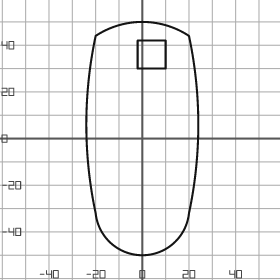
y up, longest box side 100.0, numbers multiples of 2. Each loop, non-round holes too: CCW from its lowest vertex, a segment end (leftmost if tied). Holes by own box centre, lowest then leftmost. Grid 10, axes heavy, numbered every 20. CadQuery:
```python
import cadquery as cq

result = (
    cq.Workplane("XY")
    .moveTo(-20.0, -32.0)
    .threePointArc((0.0, -50.0), (20.0, -32.0))
    .threePointArc((24.0, 6.0), (20.0, 44.0))
    .threePointArc((0.0, 50.0), (-20.0, 44.0))
    .threePointArc((-24.0, 6.0), (-20.0, -32.0))
    .close()
    .moveTo(-2.0, 30.0)
    .lineTo(10.0, 30.0)
    .lineTo(10.0, 42.0)
    .lineTo(-2.0, 42.0)
    .close()
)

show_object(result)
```